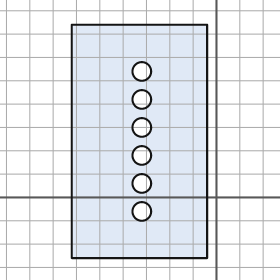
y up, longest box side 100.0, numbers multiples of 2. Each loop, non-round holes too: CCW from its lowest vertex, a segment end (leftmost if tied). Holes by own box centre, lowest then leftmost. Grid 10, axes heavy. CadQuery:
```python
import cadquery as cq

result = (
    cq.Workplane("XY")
    .moveTo(-62.0, -26.0)
    .lineTo(-4.0, -26.0)
    .lineTo(-4.0, 74.0)
    .lineTo(-62.0, 74.0)
    .close()
    .moveTo(-32.0, -6.0)
    .circle(4.0)
    .moveTo(-32.0, 6.0)
    .circle(4.0)
    .moveTo(-32.0, 18.0)
    .circle(4.0)
    .moveTo(-32.0, 30.0)
    .circle(4.0)
    .moveTo(-32.0, 42.0)
    .circle(4.0)
    .moveTo(-32.0, 54.0)
    .circle(4.0)
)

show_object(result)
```